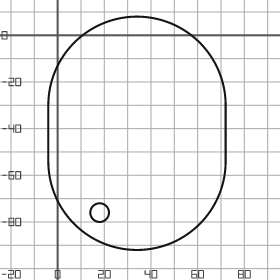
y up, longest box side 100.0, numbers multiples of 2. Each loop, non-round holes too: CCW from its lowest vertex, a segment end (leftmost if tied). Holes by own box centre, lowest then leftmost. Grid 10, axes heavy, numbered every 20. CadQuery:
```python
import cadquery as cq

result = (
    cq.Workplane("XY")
    .moveTo(-4.0, -54.0)
    .threePointArc((34.0, -92.0), (72.0, -54.0))
    .lineTo(72.0, -30.0)
    .threePointArc((34.0, 8.0), (-4.0, -30.0))
    .close()
    .moveTo(18.0, -76.0)
    .circle(4.0)
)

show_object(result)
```